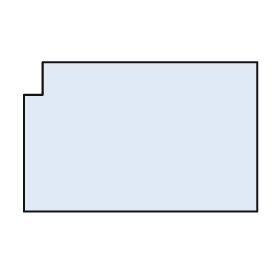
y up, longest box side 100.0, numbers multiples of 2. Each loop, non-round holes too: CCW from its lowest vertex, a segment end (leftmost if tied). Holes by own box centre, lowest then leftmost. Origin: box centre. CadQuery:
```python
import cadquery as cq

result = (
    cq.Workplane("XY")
    .moveTo(-50.0, -32.0)
    .lineTo(50.0, -32.0)
    .lineTo(50.0, 32.0)
    .lineTo(-42.0, 32.0)
    .lineTo(-42.0, 18.0)
    .lineTo(-50.0, 18.0)
    .close()
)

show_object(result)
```